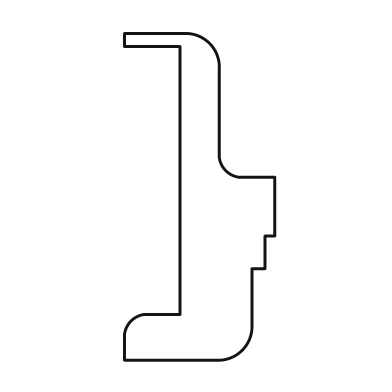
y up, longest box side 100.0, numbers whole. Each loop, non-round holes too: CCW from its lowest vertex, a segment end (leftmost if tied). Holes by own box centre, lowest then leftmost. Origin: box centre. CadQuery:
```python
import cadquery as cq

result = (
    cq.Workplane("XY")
    .moveTo(-23.0, -50.0)
    .lineTo(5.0, -50.0)
    .threePointArc((13.0, -47.0), (16.0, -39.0))
    .lineTo(16.0, -22.0)
    .lineTo(20.0, -22.0)
    .lineTo(20.0, -12.0)
    .lineTo(23.0, -12.0)
    .lineTo(23.0, 6.0)
    .lineTo(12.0, 6.0)
    .threePointArc((8.0, 8.0), (6.0, 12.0))
    .lineTo(6.0, 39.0)
    .threePointArc((3.0, 47.0), (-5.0, 50.0))
    .lineTo(-23.0, 50.0)
    .lineTo(-23.0, 46.0)
    .lineTo(-6.0, 46.0)
    .lineTo(-6.0, -36.0)
    .lineTo(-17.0, -36.0)
    .threePointArc((-21.0, -38.0), (-23.0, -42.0))
    .close()
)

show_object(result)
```